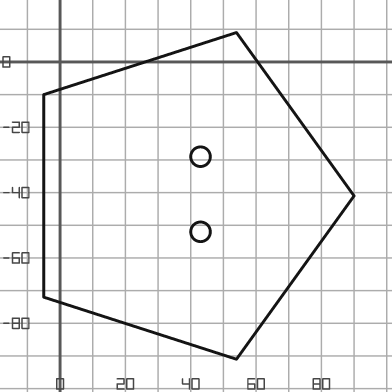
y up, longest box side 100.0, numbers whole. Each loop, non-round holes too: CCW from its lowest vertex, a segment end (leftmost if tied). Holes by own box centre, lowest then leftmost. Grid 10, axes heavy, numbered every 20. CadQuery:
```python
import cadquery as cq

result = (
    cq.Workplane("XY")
    .moveTo(54.0, -91.0)
    .lineTo(90.0, -41.0)
    .lineTo(54.0, 9.0)
    .lineTo(-5.0, -10.0)
    .lineTo(-5.0, -72.0)
    .close()
    .moveTo(43.0, -52.0)
    .circle(3.0)
    .moveTo(43.0, -29.0)
    .circle(3.0)
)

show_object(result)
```